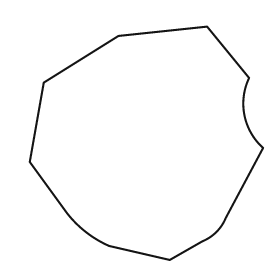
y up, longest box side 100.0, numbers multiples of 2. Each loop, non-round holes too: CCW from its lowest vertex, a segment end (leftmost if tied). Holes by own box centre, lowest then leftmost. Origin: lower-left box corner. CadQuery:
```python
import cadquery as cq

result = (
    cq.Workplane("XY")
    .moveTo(60.0, 0.0)
    .lineTo(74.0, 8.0)
    .threePointArc((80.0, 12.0), (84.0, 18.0))
    .lineTo(100.0, 48.0)
    .threePointArc((92.0, 62.0), (94.0, 78.0))
    .lineTo(76.0, 100.0)
    .lineTo(38.0, 96.0)
    .lineTo(6.0, 76.0)
    .lineTo(0.0, 42.0)
    .lineTo(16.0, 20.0)
    .threePointArc((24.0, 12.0), (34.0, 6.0))
    .close()
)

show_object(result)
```